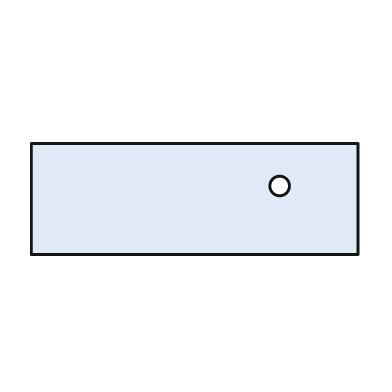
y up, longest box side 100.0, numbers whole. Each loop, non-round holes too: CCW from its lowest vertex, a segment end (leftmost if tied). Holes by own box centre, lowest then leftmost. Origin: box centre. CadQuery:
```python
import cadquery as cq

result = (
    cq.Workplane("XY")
    .moveTo(-50.0, -17.0)
    .lineTo(50.0, -17.0)
    .lineTo(50.0, 17.0)
    .lineTo(-50.0, 17.0)
    .close()
    .moveTo(26.0, 4.0)
    .circle(3.0)
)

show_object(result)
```